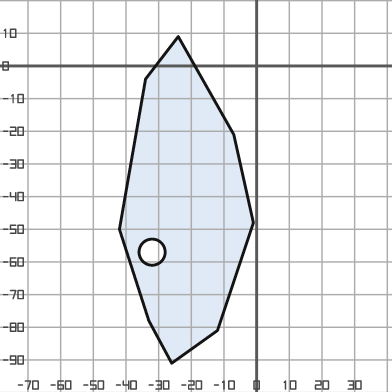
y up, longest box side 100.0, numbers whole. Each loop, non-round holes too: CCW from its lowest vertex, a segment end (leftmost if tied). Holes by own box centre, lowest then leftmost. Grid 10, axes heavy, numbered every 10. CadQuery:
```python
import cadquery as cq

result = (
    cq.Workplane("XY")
    .moveTo(-26.0, -91.0)
    .lineTo(-12.0, -81.0)
    .lineTo(-1.0, -48.0)
    .lineTo(-7.0, -21.0)
    .lineTo(-24.0, 9.0)
    .lineTo(-34.0, -4.0)
    .lineTo(-42.0, -50.0)
    .lineTo(-33.0, -78.0)
    .close()
    .moveTo(-32.0, -57.0)
    .circle(4.0)
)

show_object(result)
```